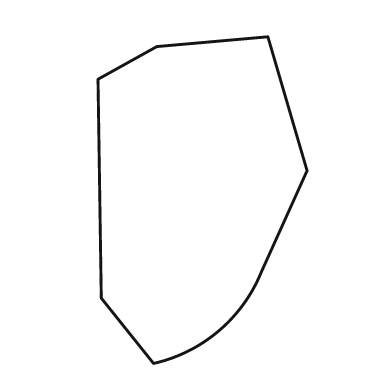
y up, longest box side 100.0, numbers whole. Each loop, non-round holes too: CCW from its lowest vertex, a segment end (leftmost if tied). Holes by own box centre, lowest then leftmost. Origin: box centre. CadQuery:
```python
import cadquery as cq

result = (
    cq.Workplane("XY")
    .moveTo(-15.0, -50.0)
    .threePointArc((5.0, -40.0), (18.0, -22.0))
    .lineTo(32.0, 9.0)
    .lineTo(20.0, 50.0)
    .lineTo(-14.0, 47.0)
    .lineTo(-32.0, 37.0)
    .lineTo(-31.0, -30.0)
    .close()
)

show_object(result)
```